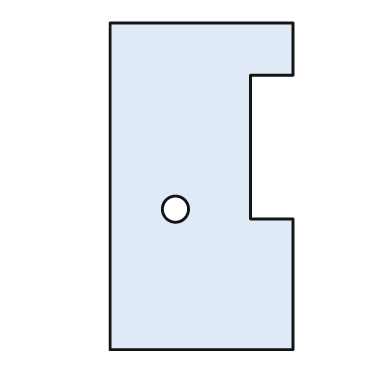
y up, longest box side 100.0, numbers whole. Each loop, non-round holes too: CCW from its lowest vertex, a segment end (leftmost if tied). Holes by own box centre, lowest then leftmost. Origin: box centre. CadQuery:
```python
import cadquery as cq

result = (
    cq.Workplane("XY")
    .moveTo(-28.0, -50.0)
    .lineTo(28.0, -50.0)
    .lineTo(28.0, -10.0)
    .lineTo(15.0, -10.0)
    .lineTo(15.0, 34.0)
    .lineTo(28.0, 34.0)
    .lineTo(28.0, 50.0)
    .lineTo(-28.0, 50.0)
    .close()
    .moveTo(-8.0, -7.0)
    .circle(4.0)
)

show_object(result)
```